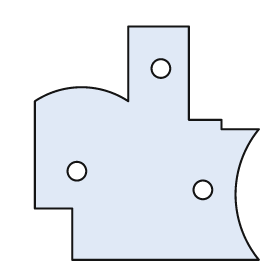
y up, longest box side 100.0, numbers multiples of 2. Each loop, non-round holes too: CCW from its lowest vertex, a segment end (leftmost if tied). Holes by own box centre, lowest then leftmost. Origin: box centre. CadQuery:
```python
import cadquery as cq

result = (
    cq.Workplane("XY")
    .moveTo(-32.0, -50.0)
    .lineTo(48.0, -50.0)
    .threePointArc((38.0, -22.0), (48.0, 6.0))
    .lineTo(32.0, 6.0)
    .lineTo(32.0, 10.0)
    .lineTo(18.0, 10.0)
    .lineTo(18.0, 50.0)
    .lineTo(-8.0, 50.0)
    .lineTo(-8.0, 18.0)
    .threePointArc((-28.0, 24.0), (-48.0, 18.0))
    .lineTo(-48.0, -28.0)
    .lineTo(-32.0, -28.0)
    .close()
    .moveTo(24.0, -20.0)
    .circle(4.0)
    .moveTo(-30.0, -12.0)
    .circle(4.0)
    .moveTo(6.0, 32.0)
    .circle(4.0)
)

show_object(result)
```